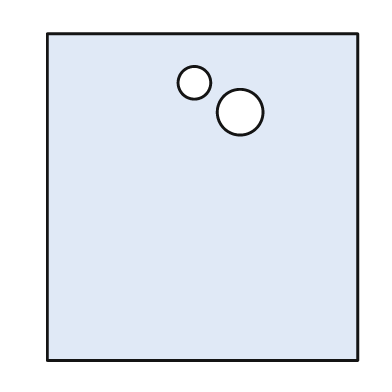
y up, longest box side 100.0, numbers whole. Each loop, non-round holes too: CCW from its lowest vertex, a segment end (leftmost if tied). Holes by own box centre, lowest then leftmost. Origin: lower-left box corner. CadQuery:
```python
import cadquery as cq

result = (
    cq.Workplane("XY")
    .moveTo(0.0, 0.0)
    .lineTo(95.0, 0.0)
    .lineTo(95.0, 100.0)
    .lineTo(0.0, 100.0)
    .close()
    .moveTo(59.0, 76.0)
    .circle(7.0)
    .moveTo(45.0, 85.0)
    .circle(5.0)
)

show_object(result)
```